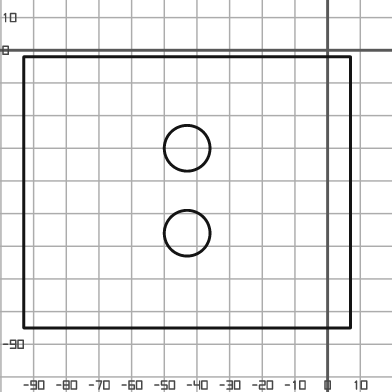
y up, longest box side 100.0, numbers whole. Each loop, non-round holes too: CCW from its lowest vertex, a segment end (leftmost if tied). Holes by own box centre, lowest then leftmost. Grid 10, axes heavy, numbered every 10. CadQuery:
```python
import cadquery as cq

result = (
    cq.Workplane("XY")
    .moveTo(-93.0, -85.0)
    .lineTo(7.0, -85.0)
    .lineTo(7.0, -2.0)
    .lineTo(-93.0, -2.0)
    .close()
    .moveTo(-43.0, -56.0)
    .circle(7.0)
    .moveTo(-43.0, -30.0)
    .circle(7.0)
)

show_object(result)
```